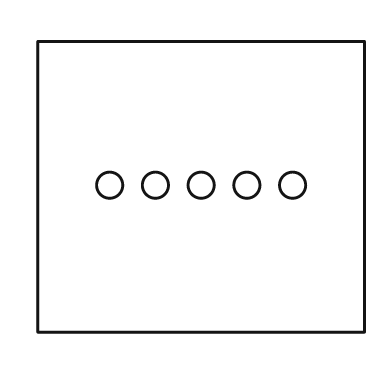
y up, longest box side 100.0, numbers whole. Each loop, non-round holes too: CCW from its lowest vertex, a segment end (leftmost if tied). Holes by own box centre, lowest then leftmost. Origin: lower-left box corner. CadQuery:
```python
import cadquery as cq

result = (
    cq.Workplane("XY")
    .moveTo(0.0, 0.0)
    .lineTo(100.0, 0.0)
    .lineTo(100.0, 89.0)
    .lineTo(0.0, 89.0)
    .close()
    .moveTo(22.0, 45.0)
    .circle(4.0)
    .moveTo(36.0, 45.0)
    .circle(4.0)
    .moveTo(50.0, 45.0)
    .circle(4.0)
    .moveTo(64.0, 45.0)
    .circle(4.0)
    .moveTo(78.0, 45.0)
    .circle(4.0)
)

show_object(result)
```